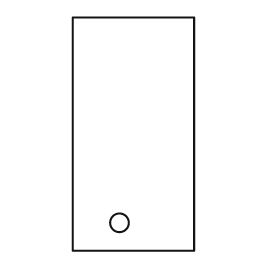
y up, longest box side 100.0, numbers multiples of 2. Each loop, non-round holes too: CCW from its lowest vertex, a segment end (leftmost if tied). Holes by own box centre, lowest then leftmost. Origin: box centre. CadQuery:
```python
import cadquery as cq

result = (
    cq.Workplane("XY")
    .moveTo(-26.0, -50.0)
    .lineTo(26.0, -50.0)
    .lineTo(26.0, 50.0)
    .lineTo(-26.0, 50.0)
    .close()
    .moveTo(-6.0, -38.0)
    .circle(4.0)
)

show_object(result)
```